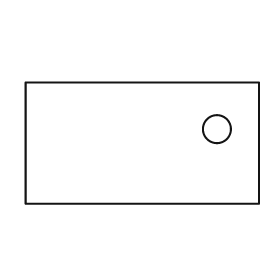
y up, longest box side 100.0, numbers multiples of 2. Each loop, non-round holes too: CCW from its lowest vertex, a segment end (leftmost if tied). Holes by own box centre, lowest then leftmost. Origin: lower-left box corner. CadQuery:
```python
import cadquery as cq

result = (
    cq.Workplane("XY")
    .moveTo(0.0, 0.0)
    .lineTo(100.0, 0.0)
    .lineTo(100.0, 52.0)
    .lineTo(0.0, 52.0)
    .close()
    .moveTo(82.0, 32.0)
    .circle(6.0)
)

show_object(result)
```